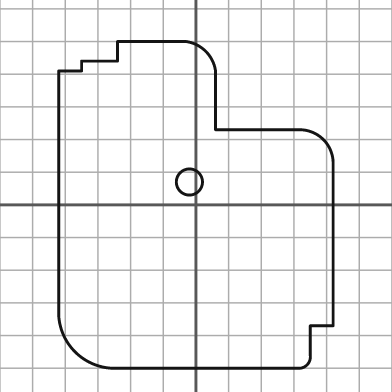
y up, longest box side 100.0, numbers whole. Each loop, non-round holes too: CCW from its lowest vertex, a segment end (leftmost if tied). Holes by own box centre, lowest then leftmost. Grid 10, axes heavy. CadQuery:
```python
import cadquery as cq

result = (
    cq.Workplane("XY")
    .moveTo(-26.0, -50.0)
    .lineTo(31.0, -50.0)
    .threePointArc((34.0, -49.0), (35.0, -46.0))
    .lineTo(35.0, -37.0)
    .lineTo(42.0, -37.0)
    .lineTo(42.0, 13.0)
    .threePointArc((39.0, 20.0), (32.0, 23.0))
    .lineTo(6.0, 23.0)
    .lineTo(6.0, 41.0)
    .threePointArc((3.0, 47.0), (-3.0, 50.0))
    .lineTo(-24.0, 50.0)
    .lineTo(-24.0, 44.0)
    .lineTo(-35.0, 44.0)
    .lineTo(-35.0, 41.0)
    .lineTo(-42.0, 41.0)
    .lineTo(-42.0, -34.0)
    .threePointArc((-37.0, -45.0), (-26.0, -50.0))
    .close()
    .moveTo(-2.0, 7.0)
    .circle(4.0)
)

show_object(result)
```